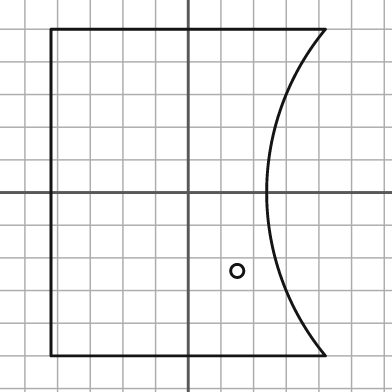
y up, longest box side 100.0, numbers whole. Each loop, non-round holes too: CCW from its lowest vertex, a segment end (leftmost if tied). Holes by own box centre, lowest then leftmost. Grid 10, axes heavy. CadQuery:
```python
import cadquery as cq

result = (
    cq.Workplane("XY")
    .moveTo(-42.0, -50.0)
    .lineTo(42.0, -50.0)
    .threePointArc((24.0, 0.0), (42.0, 50.0))
    .lineTo(-42.0, 50.0)
    .close()
    .moveTo(15.0, -24.0)
    .circle(2.0)
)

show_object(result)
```